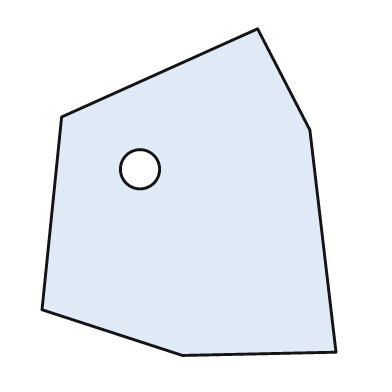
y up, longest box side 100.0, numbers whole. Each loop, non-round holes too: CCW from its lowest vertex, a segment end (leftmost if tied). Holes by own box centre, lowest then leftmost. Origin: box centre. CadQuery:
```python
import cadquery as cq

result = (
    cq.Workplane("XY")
    .moveTo(-2.0, -50.0)
    .lineTo(45.0, -49.0)
    .lineTo(37.0, 19.0)
    .lineTo(21.0, 50.0)
    .lineTo(-39.0, 23.0)
    .lineTo(-45.0, -36.0)
    .close()
    .moveTo(-15.0, 7.0)
    .circle(6.0)
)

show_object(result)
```